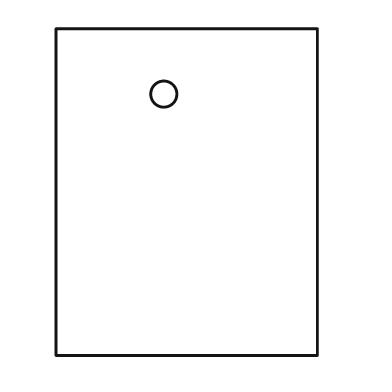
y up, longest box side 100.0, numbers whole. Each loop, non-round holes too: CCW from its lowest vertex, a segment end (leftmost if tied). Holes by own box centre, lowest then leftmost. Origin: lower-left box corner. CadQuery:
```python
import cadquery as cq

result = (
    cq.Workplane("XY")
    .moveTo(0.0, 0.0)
    .lineTo(80.0, 0.0)
    .lineTo(80.0, 100.0)
    .lineTo(0.0, 100.0)
    .close()
    .moveTo(33.0, 80.0)
    .circle(4.0)
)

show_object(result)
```